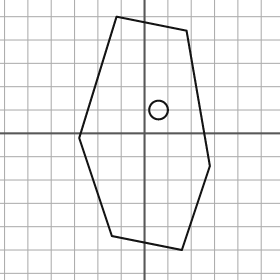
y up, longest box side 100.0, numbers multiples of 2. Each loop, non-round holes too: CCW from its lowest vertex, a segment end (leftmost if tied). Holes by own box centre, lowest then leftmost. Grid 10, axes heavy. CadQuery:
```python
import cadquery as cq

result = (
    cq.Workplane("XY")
    .moveTo(16.0, -50.0)
    .lineTo(28.0, -14.0)
    .lineTo(18.0, 44.0)
    .lineTo(-12.0, 50.0)
    .lineTo(-28.0, -2.0)
    .lineTo(-14.0, -44.0)
    .close()
    .moveTo(6.0, 10.0)
    .circle(4.0)
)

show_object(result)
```